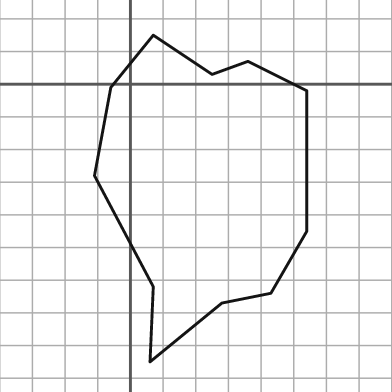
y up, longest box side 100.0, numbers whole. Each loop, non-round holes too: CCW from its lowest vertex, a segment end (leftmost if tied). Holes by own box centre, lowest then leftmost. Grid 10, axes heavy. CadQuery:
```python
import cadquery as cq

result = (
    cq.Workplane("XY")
    .moveTo(6.0, -85.0)
    .lineTo(28.0, -67.0)
    .lineTo(43.0, -64.0)
    .lineTo(54.0, -45.0)
    .lineTo(54.0, -2.0)
    .lineTo(36.0, 7.0)
    .lineTo(25.0, 3.0)
    .lineTo(7.0, 15.0)
    .lineTo(-6.0, -1.0)
    .lineTo(-11.0, -28.0)
    .lineTo(7.0, -62.0)
    .close()
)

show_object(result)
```